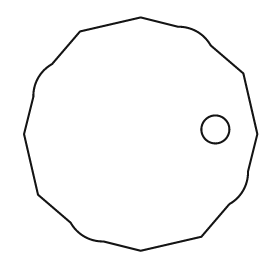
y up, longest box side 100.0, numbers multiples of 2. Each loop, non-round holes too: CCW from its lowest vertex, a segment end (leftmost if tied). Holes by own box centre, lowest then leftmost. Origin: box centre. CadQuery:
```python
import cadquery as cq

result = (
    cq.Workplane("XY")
    .moveTo(0.0, -50.0)
    .lineTo(26.0, -44.0)
    .lineTo(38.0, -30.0)
    .threePointArc((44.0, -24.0), (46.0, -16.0))
    .lineTo(50.0, 0.0)
    .lineTo(44.0, 26.0)
    .lineTo(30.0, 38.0)
    .threePointArc((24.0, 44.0), (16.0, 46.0))
    .lineTo(0.0, 50.0)
    .lineTo(-26.0, 44.0)
    .lineTo(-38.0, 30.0)
    .threePointArc((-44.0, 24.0), (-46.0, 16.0))
    .lineTo(-50.0, 0.0)
    .lineTo(-44.0, -26.0)
    .lineTo(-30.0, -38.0)
    .threePointArc((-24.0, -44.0), (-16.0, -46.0))
    .close()
    .moveTo(32.0, 2.0)
    .circle(6.0)
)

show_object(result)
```